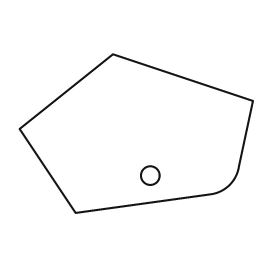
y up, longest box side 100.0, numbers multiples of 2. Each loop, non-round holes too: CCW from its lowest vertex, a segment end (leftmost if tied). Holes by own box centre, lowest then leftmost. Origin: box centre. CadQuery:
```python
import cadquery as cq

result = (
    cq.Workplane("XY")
    .moveTo(-26.0, -34.0)
    .lineTo(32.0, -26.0)
    .threePointArc((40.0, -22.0), (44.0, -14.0))
    .lineTo(50.0, 14.0)
    .lineTo(-10.0, 34.0)
    .lineTo(-50.0, 2.0)
    .close()
    .moveTo(6.0, -18.0)
    .circle(4.0)
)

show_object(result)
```